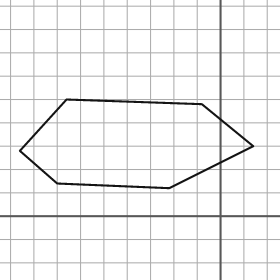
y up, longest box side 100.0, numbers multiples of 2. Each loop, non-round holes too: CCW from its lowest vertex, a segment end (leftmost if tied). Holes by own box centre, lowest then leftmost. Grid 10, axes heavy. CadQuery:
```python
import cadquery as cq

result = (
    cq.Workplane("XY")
    .moveTo(-22.0, 12.0)
    .lineTo(14.0, 30.0)
    .lineTo(-8.0, 48.0)
    .lineTo(-66.0, 50.0)
    .lineTo(-86.0, 28.0)
    .lineTo(-70.0, 14.0)
    .close()
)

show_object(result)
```